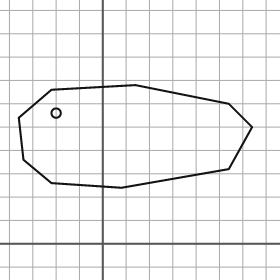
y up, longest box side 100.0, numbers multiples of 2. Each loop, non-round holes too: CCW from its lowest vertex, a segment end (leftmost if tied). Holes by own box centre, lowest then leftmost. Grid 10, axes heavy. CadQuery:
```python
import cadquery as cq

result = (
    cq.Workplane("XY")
    .moveTo(8.0, 24.0)
    .lineTo(54.0, 32.0)
    .lineTo(64.0, 50.0)
    .lineTo(54.0, 60.0)
    .lineTo(14.0, 68.0)
    .lineTo(-22.0, 66.0)
    .lineTo(-36.0, 54.0)
    .lineTo(-34.0, 36.0)
    .lineTo(-22.0, 26.0)
    .close()
    .moveTo(-20.0, 56.0)
    .circle(2.0)
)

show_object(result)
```